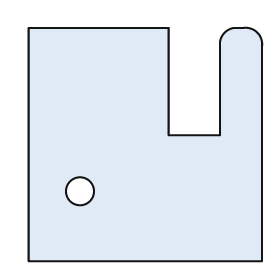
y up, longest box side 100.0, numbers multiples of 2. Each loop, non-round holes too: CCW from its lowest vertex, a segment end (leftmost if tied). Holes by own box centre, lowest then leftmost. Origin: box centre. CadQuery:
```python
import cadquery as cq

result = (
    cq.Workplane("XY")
    .moveTo(-50.0, -50.0)
    .lineTo(50.0, -50.0)
    .lineTo(50.0, 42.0)
    .threePointArc((48.0, 48.0), (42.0, 50.0))
    .lineTo(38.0, 50.0)
    .threePointArc((34.0, 48.0), (32.0, 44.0))
    .lineTo(32.0, 4.0)
    .lineTo(10.0, 4.0)
    .lineTo(10.0, 50.0)
    .lineTo(-50.0, 50.0)
    .close()
    .moveTo(-28.0, -20.0)
    .circle(6.0)
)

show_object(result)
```